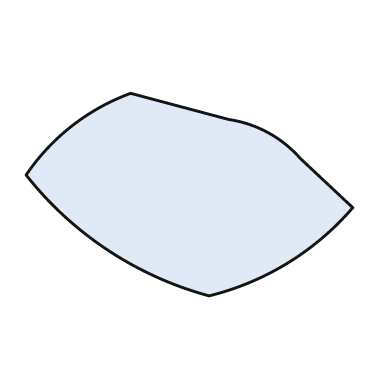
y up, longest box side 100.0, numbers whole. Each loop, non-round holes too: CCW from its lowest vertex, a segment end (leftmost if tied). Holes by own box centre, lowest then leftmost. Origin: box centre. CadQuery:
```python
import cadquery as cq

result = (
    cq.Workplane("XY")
    .moveTo(6.0, -31.0)
    .threePointArc((30.0, -21.0), (50.0, -4.0))
    .lineTo(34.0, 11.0)
    .threePointArc((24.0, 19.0), (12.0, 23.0))
    .lineTo(-18.0, 31.0)
    .threePointArc((-36.0, 21.0), (-50.0, 6.0))
    .threePointArc((-25.0, -17.0), (6.0, -31.0))
    .close()
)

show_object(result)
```